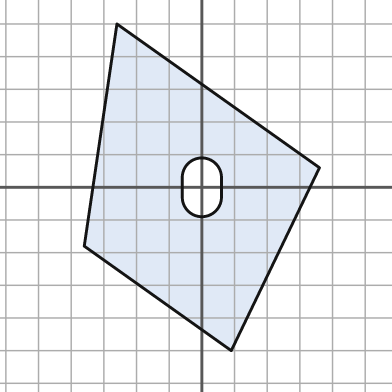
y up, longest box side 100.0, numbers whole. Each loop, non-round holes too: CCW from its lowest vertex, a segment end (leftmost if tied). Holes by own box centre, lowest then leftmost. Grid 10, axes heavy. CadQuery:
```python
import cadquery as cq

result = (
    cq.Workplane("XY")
    .moveTo(9.0, -50.0)
    .lineTo(36.0, 6.0)
    .lineTo(-26.0, 50.0)
    .lineTo(-36.0, -18.0)
    .close()
    .moveTo(-6.0, -3.0)
    .threePointArc((0.0, -9.0), (6.0, -3.0))
    .lineTo(6.0, 3.0)
    .threePointArc((0.0, 9.0), (-6.0, 3.0))
    .close()
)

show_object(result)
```